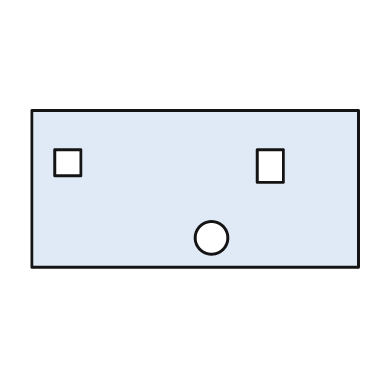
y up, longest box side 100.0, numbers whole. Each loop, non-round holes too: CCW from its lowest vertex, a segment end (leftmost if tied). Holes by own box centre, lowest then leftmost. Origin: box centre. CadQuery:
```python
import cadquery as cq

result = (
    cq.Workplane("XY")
    .moveTo(-50.0, -24.0)
    .lineTo(50.0, -24.0)
    .lineTo(50.0, 24.0)
    .lineTo(-50.0, 24.0)
    .close()
    .moveTo(5.0, -15.0)
    .circle(5.0)
    .moveTo(19.0, 2.0)
    .lineTo(27.0, 2.0)
    .lineTo(27.0, 12.0)
    .lineTo(19.0, 12.0)
    .close()
    .moveTo(-43.0, 4.0)
    .lineTo(-35.0, 4.0)
    .lineTo(-35.0, 12.0)
    .lineTo(-43.0, 12.0)
    .close()
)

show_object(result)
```